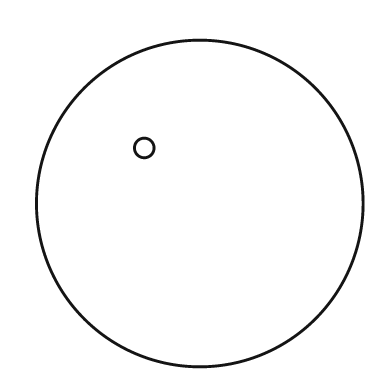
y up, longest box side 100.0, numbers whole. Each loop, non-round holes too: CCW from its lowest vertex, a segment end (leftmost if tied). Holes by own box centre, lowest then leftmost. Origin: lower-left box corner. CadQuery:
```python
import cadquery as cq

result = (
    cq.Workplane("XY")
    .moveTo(50.0, 50.0)
    .circle(50.0)
    .moveTo(33.0, 67.0)
    .circle(3.0)
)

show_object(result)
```